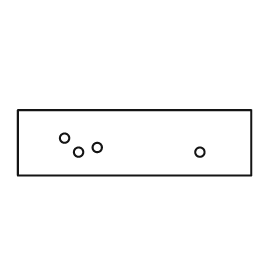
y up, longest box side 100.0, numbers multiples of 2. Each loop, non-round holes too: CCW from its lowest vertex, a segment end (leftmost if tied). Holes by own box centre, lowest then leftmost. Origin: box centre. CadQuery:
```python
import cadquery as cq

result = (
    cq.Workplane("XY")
    .moveTo(-50.0, -14.0)
    .lineTo(50.0, -14.0)
    .lineTo(50.0, 14.0)
    .lineTo(-50.0, 14.0)
    .close()
    .moveTo(-24.0, -4.0)
    .circle(2.0)
    .moveTo(28.0, -4.0)
    .circle(2.0)
    .moveTo(-16.0, -2.0)
    .circle(2.0)
    .moveTo(-30.0, 2.0)
    .circle(2.0)
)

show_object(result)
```